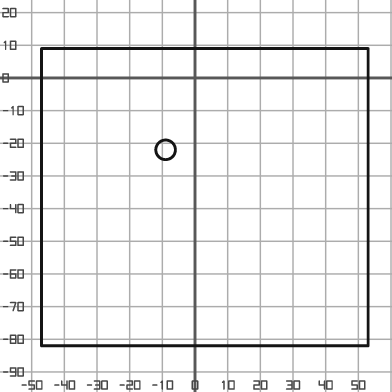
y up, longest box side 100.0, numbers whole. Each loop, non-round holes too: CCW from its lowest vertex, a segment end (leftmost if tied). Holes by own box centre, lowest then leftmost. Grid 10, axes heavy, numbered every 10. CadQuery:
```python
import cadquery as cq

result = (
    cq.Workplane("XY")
    .moveTo(-47.0, -82.0)
    .lineTo(53.0, -82.0)
    .lineTo(53.0, 9.0)
    .lineTo(-47.0, 9.0)
    .close()
    .moveTo(-9.0, -22.0)
    .circle(3.0)
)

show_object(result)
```